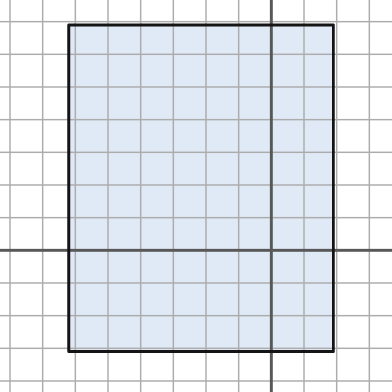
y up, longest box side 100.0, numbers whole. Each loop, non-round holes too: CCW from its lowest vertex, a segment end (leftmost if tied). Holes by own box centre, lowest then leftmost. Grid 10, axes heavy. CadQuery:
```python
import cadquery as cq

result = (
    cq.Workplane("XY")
    .moveTo(-62.0, -31.0)
    .lineTo(19.0, -31.0)
    .lineTo(19.0, 69.0)
    .lineTo(-62.0, 69.0)
    .close()
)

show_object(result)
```